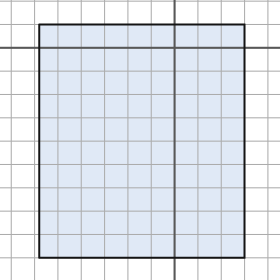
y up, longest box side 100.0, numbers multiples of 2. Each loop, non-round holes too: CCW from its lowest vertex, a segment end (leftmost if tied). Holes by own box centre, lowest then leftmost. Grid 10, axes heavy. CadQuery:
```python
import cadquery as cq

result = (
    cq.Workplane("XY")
    .moveTo(-58.0, -90.0)
    .lineTo(30.0, -90.0)
    .lineTo(30.0, 10.0)
    .lineTo(-58.0, 10.0)
    .close()
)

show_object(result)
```